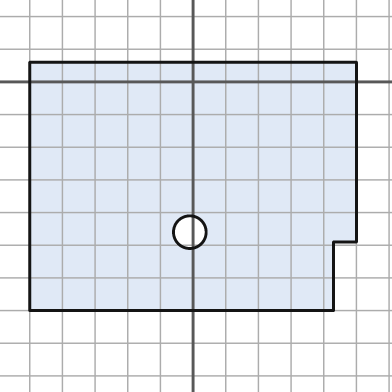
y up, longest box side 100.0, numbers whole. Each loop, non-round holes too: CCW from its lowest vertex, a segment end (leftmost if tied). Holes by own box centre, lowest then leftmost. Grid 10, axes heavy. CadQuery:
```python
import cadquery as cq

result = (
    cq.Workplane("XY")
    .moveTo(-50.0, -70.0)
    .lineTo(43.0, -70.0)
    .lineTo(43.0, -49.0)
    .lineTo(50.0, -49.0)
    .lineTo(50.0, 6.0)
    .lineTo(-50.0, 6.0)
    .close()
    .moveTo(-1.0, -46.0)
    .circle(5.0)
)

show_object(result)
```